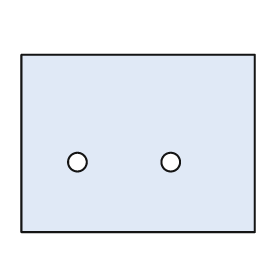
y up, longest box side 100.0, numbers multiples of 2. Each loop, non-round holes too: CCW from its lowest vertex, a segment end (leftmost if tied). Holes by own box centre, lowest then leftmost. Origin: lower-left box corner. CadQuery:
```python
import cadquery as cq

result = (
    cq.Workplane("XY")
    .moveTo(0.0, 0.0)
    .lineTo(100.0, 0.0)
    .lineTo(100.0, 76.0)
    .lineTo(0.0, 76.0)
    .close()
    .moveTo(24.0, 30.0)
    .circle(4.0)
    .moveTo(64.0, 30.0)
    .circle(4.0)
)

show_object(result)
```